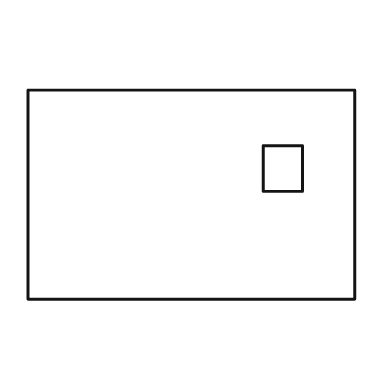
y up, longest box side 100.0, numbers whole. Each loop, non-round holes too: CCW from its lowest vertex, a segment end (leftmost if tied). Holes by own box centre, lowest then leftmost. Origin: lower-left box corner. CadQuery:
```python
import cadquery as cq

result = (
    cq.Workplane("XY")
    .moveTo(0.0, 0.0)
    .lineTo(100.0, 0.0)
    .lineTo(100.0, 64.0)
    .lineTo(0.0, 64.0)
    .close()
    .moveTo(72.0, 33.0)
    .lineTo(84.0, 33.0)
    .lineTo(84.0, 47.0)
    .lineTo(72.0, 47.0)
    .close()
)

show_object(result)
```